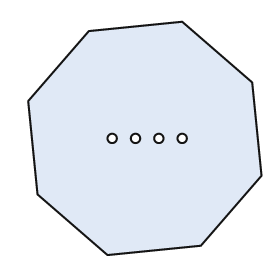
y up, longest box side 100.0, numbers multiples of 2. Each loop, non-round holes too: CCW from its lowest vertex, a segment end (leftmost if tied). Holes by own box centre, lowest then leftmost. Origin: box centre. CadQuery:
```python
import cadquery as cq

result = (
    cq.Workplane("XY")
    .moveTo(-16.0, -50.0)
    .lineTo(24.0, -46.0)
    .lineTo(50.0, -16.0)
    .lineTo(46.0, 24.0)
    .lineTo(16.0, 50.0)
    .lineTo(-24.0, 46.0)
    .lineTo(-50.0, 16.0)
    .lineTo(-46.0, -24.0)
    .close()
    .moveTo(-14.0, 0.0)
    .circle(2.0)
    .moveTo(-4.0, 0.0)
    .circle(2.0)
    .moveTo(6.0, 0.0)
    .circle(2.0)
    .moveTo(16.0, 0.0)
    .circle(2.0)
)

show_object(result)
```